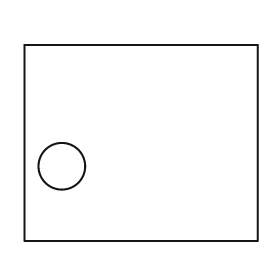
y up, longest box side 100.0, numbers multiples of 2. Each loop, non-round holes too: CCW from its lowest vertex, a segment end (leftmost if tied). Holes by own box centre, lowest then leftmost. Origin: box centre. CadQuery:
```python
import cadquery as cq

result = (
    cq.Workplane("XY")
    .moveTo(-50.0, -42.0)
    .lineTo(50.0, -42.0)
    .lineTo(50.0, 42.0)
    .lineTo(-50.0, 42.0)
    .close()
    .moveTo(-34.0, -10.0)
    .circle(10.0)
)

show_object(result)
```